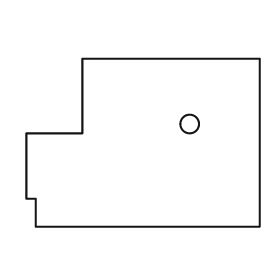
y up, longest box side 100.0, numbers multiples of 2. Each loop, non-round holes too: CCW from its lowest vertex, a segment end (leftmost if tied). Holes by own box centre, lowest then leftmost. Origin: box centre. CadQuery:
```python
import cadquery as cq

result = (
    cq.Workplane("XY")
    .moveTo(-46.0, -36.0)
    .lineTo(50.0, -36.0)
    .lineTo(50.0, 36.0)
    .lineTo(-26.0, 36.0)
    .lineTo(-26.0, 4.0)
    .lineTo(-50.0, 4.0)
    .lineTo(-50.0, -24.0)
    .lineTo(-46.0, -24.0)
    .close()
    .moveTo(20.0, 8.0)
    .circle(4.0)
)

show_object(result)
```